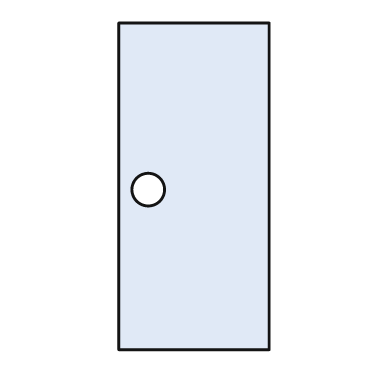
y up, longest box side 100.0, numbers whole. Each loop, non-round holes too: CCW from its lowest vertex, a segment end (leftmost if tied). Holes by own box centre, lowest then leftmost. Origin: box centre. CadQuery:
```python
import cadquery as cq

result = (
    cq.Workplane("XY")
    .moveTo(-23.0, -50.0)
    .lineTo(23.0, -50.0)
    .lineTo(23.0, 50.0)
    .lineTo(-23.0, 50.0)
    .close()
    .moveTo(-14.0, -1.0)
    .circle(5.0)
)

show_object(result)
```